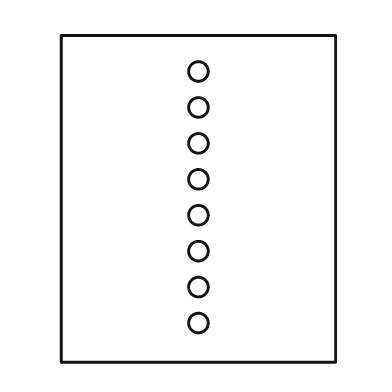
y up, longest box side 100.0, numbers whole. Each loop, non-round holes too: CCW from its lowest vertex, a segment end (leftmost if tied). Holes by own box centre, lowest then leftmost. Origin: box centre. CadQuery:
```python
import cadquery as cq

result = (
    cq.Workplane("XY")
    .moveTo(-42.0, -50.0)
    .lineTo(42.0, -50.0)
    .lineTo(42.0, 50.0)
    .lineTo(-42.0, 50.0)
    .close()
    .moveTo(0.0, -38.0)
    .circle(3.0)
    .moveTo(0.0, -27.0)
    .circle(3.0)
    .moveTo(0.0, -16.0)
    .circle(3.0)
    .moveTo(0.0, -5.0)
    .circle(3.0)
    .moveTo(0.0, 6.0)
    .circle(3.0)
    .moveTo(0.0, 17.0)
    .circle(3.0)
    .moveTo(0.0, 28.0)
    .circle(3.0)
    .moveTo(0.0, 39.0)
    .circle(3.0)
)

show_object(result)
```